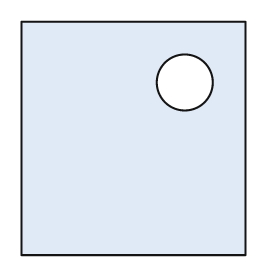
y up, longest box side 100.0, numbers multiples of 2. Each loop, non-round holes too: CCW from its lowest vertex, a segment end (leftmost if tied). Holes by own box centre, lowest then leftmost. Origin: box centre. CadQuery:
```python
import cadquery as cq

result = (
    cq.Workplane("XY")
    .moveTo(-48.0, -50.0)
    .lineTo(48.0, -50.0)
    .lineTo(48.0, 50.0)
    .lineTo(-48.0, 50.0)
    .close()
    .moveTo(22.0, 24.0)
    .circle(12.0)
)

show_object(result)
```